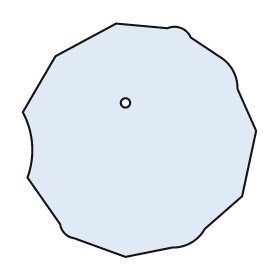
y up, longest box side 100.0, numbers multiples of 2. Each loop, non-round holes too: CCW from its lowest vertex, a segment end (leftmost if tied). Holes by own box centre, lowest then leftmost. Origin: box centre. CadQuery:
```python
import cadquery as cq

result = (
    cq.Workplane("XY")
    .moveTo(-6.0, -50.0)
    .lineTo(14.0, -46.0)
    .threePointArc((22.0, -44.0), (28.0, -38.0))
    .lineTo(44.0, -24.0)
    .lineTo(50.0, 4.0)
    .lineTo(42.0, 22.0)
    .threePointArc((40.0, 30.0), (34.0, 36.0))
    .lineTo(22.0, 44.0)
    .threePointArc((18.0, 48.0), (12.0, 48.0))
    .lineTo(-10.0, 50.0)
    .lineTo(-36.0, 36.0)
    .lineTo(-50.0, 12.0)
    .threePointArc((-46.0, -2.0), (-48.0, -16.0))
    .lineTo(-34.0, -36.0)
    .threePointArc((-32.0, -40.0), (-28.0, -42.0))
    .close()
    .moveTo(-6.0, 16.0)
    .circle(2.0)
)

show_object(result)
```